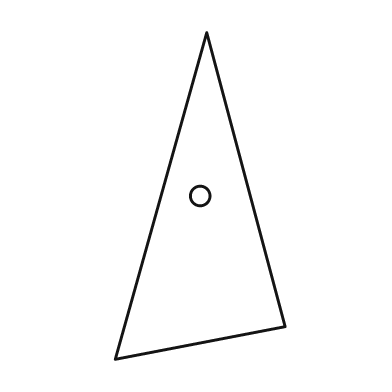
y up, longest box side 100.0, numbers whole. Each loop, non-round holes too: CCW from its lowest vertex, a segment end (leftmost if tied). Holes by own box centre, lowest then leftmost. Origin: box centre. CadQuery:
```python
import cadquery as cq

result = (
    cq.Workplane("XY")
    .moveTo(-26.0, -50.0)
    .lineTo(26.0, -40.0)
    .lineTo(2.0, 50.0)
    .close()
    .moveTo(0.0, 0.0)
    .circle(3.0)
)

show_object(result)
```